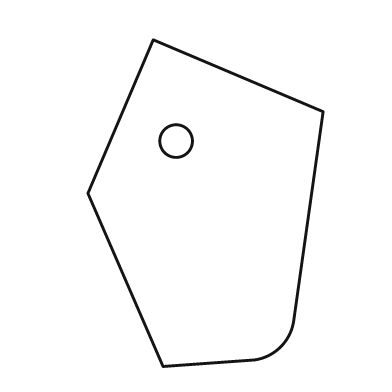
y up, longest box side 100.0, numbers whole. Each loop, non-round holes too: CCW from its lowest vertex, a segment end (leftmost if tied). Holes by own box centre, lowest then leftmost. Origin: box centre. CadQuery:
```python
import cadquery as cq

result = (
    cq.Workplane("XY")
    .moveTo(-13.0, -50.0)
    .lineTo(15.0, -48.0)
    .threePointArc((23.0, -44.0), (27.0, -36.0))
    .lineTo(36.0, 28.0)
    .lineTo(-16.0, 50.0)
    .lineTo(-36.0, 3.0)
    .close()
    .moveTo(-9.0, 19.0)
    .circle(5.0)
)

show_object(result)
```